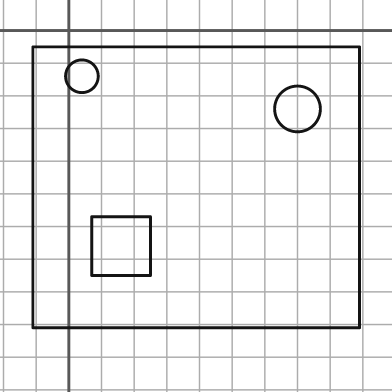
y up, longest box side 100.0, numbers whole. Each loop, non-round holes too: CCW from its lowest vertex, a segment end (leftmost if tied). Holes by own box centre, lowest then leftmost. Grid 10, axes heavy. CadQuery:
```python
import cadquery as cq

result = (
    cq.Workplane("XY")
    .moveTo(-11.0, -91.0)
    .lineTo(89.0, -91.0)
    .lineTo(89.0, -5.0)
    .lineTo(-11.0, -5.0)
    .close()
    .moveTo(7.0, -75.0)
    .lineTo(25.0, -75.0)
    .lineTo(25.0, -57.0)
    .lineTo(7.0, -57.0)
    .close()
    .moveTo(70.0, -24.0)
    .circle(7.0)
    .moveTo(4.0, -14.0)
    .circle(5.0)
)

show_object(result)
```